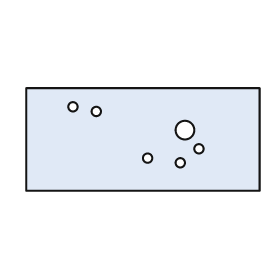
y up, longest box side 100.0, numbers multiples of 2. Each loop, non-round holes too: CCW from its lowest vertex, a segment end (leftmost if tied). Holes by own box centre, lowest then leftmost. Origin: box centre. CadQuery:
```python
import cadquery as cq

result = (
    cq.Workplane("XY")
    .moveTo(-50.0, -22.0)
    .lineTo(50.0, -22.0)
    .lineTo(50.0, 22.0)
    .lineTo(-50.0, 22.0)
    .close()
    .moveTo(16.0, -10.0)
    .circle(2.0)
    .moveTo(2.0, -8.0)
    .circle(2.0)
    .moveTo(24.0, -4.0)
    .circle(2.0)
    .moveTo(18.0, 4.0)
    .circle(4.0)
    .moveTo(-20.0, 12.0)
    .circle(2.0)
    .moveTo(-30.0, 14.0)
    .circle(2.0)
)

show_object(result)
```